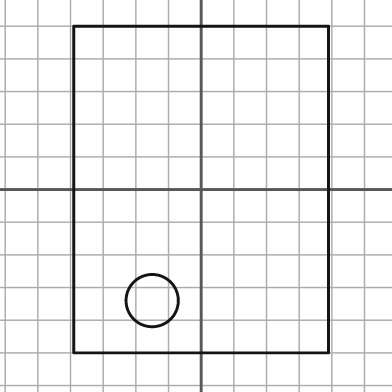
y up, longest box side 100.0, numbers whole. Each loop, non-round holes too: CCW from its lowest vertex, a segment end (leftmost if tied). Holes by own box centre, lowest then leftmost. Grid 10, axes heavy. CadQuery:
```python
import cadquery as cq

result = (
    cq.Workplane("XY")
    .moveTo(-39.0, -50.0)
    .lineTo(39.0, -50.0)
    .lineTo(39.0, 50.0)
    .lineTo(-39.0, 50.0)
    .close()
    .moveTo(-15.0, -34.0)
    .circle(8.0)
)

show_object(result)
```